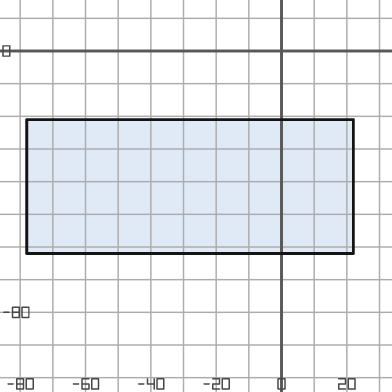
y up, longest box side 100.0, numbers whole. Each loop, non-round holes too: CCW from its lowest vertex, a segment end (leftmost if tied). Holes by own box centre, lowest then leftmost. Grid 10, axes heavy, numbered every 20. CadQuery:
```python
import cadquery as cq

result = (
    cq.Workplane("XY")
    .moveTo(-78.0, -62.0)
    .lineTo(22.0, -62.0)
    .lineTo(22.0, -21.0)
    .lineTo(-78.0, -21.0)
    .close()
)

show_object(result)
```